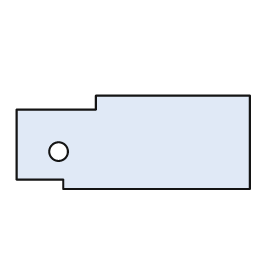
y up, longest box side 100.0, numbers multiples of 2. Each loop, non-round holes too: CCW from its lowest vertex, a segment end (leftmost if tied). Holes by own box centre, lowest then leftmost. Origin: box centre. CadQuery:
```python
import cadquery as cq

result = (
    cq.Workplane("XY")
    .moveTo(-30.0, -20.0)
    .lineTo(50.0, -20.0)
    .lineTo(50.0, 20.0)
    .lineTo(-16.0, 20.0)
    .lineTo(-16.0, 14.0)
    .lineTo(-50.0, 14.0)
    .lineTo(-50.0, -16.0)
    .lineTo(-30.0, -16.0)
    .close()
    .moveTo(-32.0, -4.0)
    .circle(4.0)
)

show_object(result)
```